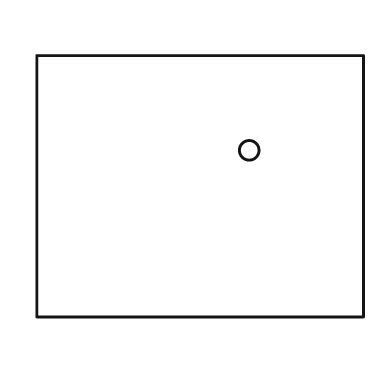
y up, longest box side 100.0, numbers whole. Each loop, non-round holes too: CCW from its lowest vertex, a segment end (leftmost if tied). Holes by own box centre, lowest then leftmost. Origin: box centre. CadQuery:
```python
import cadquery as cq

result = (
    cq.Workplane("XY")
    .moveTo(-50.0, -40.0)
    .lineTo(50.0, -40.0)
    .lineTo(50.0, 40.0)
    .lineTo(-50.0, 40.0)
    .close()
    .moveTo(15.0, 11.0)
    .circle(3.0)
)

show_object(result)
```